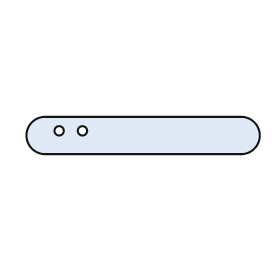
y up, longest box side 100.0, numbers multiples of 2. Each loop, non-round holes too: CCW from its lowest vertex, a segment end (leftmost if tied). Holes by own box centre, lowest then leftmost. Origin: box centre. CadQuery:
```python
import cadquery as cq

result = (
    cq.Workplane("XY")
    .moveTo(-42.0, -8.0)
    .lineTo(42.0, -8.0)
    .threePointArc((50.0, 0.0), (42.0, 8.0))
    .lineTo(-42.0, 8.0)
    .threePointArc((-50.0, 0.0), (-42.0, -8.0))
    .close()
    .moveTo(-36.0, 2.0)
    .circle(2.0)
    .moveTo(-26.0, 2.0)
    .circle(2.0)
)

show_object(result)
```